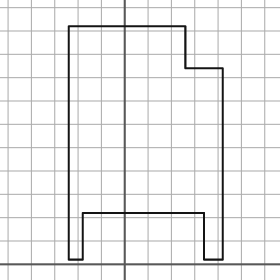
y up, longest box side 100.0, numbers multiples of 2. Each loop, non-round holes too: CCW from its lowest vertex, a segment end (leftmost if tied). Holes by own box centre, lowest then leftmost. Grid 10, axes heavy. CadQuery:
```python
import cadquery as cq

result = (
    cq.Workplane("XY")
    .moveTo(-24.0, 2.0)
    .lineTo(-18.0, 2.0)
    .lineTo(-18.0, 22.0)
    .lineTo(34.0, 22.0)
    .lineTo(34.0, 2.0)
    .lineTo(42.0, 2.0)
    .lineTo(42.0, 84.0)
    .lineTo(26.0, 84.0)
    .lineTo(26.0, 102.0)
    .lineTo(-24.0, 102.0)
    .close()
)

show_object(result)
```